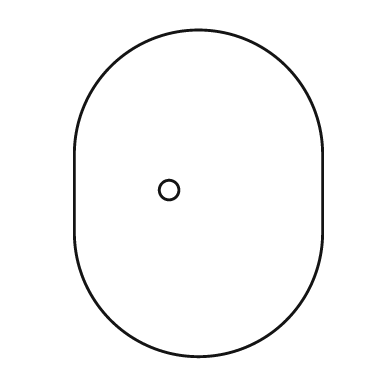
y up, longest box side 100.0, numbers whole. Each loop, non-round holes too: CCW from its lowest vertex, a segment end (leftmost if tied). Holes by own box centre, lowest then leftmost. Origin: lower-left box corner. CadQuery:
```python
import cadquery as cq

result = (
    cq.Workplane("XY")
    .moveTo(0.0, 38.0)
    .threePointArc((38.0, 0.0), (76.0, 38.0))
    .lineTo(76.0, 62.0)
    .threePointArc((38.0, 100.0), (0.0, 62.0))
    .close()
    .moveTo(29.0, 51.0)
    .circle(3.0)
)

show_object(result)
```